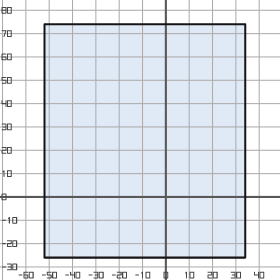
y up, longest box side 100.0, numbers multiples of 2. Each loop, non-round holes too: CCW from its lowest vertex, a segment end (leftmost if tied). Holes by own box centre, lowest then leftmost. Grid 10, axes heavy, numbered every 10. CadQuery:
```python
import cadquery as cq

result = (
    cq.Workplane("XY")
    .moveTo(-52.0, -26.0)
    .lineTo(34.0, -26.0)
    .lineTo(34.0, 74.0)
    .lineTo(-52.0, 74.0)
    .close()
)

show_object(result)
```